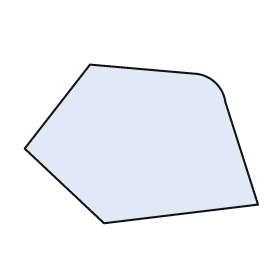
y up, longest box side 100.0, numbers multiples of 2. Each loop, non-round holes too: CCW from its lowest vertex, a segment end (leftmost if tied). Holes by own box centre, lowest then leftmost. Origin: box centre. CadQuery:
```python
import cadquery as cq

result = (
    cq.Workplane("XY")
    .moveTo(-16.0, -34.0)
    .lineTo(50.0, -26.0)
    .lineTo(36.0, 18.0)
    .threePointArc((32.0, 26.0), (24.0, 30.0))
    .lineTo(-22.0, 34.0)
    .lineTo(-50.0, -2.0)
    .close()
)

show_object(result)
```